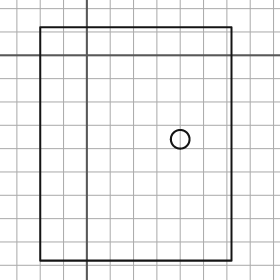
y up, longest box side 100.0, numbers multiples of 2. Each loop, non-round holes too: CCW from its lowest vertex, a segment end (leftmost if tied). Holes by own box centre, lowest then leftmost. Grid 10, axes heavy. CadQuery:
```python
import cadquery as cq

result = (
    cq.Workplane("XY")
    .moveTo(-20.0, -88.0)
    .lineTo(62.0, -88.0)
    .lineTo(62.0, 12.0)
    .lineTo(-20.0, 12.0)
    .close()
    .moveTo(40.0, -36.0)
    .circle(4.0)
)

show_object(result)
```